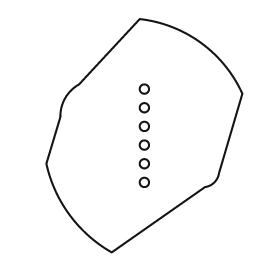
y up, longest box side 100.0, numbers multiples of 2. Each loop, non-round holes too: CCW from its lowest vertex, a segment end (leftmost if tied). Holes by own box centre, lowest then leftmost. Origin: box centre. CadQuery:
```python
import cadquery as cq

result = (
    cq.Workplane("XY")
    .moveTo(-14.0, -50.0)
    .lineTo(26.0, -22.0)
    .threePointArc((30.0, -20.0), (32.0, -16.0))
    .lineTo(42.0, 18.0)
    .threePointArc((24.0, 40.0), (-2.0, 50.0))
    .lineTo(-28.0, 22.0)
    .threePointArc((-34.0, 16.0), (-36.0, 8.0))
    .lineTo(-42.0, -12.0)
    .threePointArc((-32.0, -34.0), (-14.0, -50.0))
    .close()
    .moveTo(0.0, -20.0)
    .circle(2.0)
    .moveTo(0.0, -12.0)
    .circle(2.0)
    .moveTo(0.0, -4.0)
    .circle(2.0)
    .moveTo(0.0, 4.0)
    .circle(2.0)
    .moveTo(0.0, 12.0)
    .circle(2.0)
    .moveTo(0.0, 20.0)
    .circle(2.0)
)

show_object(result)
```